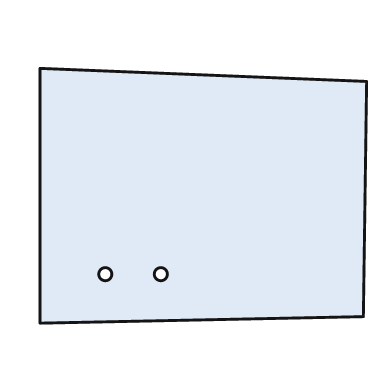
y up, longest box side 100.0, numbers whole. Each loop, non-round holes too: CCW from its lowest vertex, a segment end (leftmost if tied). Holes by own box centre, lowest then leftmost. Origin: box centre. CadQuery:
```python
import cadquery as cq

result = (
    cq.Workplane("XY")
    .moveTo(-50.0, -39.0)
    .lineTo(49.0, -37.0)
    .lineTo(50.0, 35.0)
    .lineTo(-50.0, 39.0)
    .close()
    .moveTo(-30.0, -24.0)
    .circle(2.0)
    .moveTo(-13.0, -24.0)
    .circle(2.0)
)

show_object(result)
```